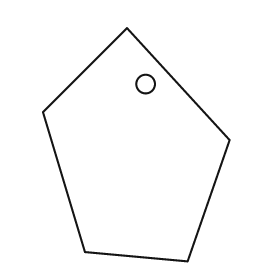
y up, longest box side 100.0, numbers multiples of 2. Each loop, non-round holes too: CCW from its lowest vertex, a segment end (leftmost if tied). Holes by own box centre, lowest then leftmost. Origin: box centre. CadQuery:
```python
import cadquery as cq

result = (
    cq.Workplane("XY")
    .moveTo(22.0, -50.0)
    .lineTo(40.0, 2.0)
    .lineTo(-4.0, 50.0)
    .lineTo(-40.0, 14.0)
    .lineTo(-22.0, -46.0)
    .close()
    .moveTo(4.0, 26.0)
    .circle(4.0)
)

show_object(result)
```